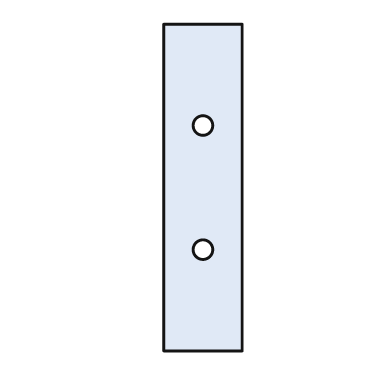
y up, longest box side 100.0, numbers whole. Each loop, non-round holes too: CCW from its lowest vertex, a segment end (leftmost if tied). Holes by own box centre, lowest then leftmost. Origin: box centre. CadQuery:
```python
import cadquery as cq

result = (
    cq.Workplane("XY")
    .moveTo(-12.0, -50.0)
    .lineTo(12.0, -50.0)
    .lineTo(12.0, 50.0)
    .lineTo(-12.0, 50.0)
    .close()
    .moveTo(0.0, -19.0)
    .circle(3.0)
    .moveTo(0.0, 19.0)
    .circle(3.0)
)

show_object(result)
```